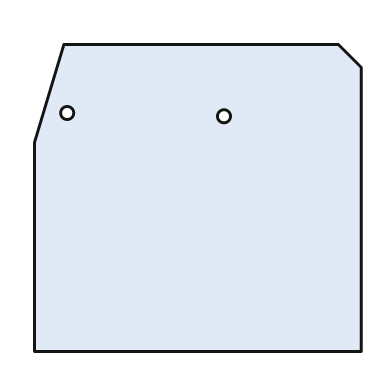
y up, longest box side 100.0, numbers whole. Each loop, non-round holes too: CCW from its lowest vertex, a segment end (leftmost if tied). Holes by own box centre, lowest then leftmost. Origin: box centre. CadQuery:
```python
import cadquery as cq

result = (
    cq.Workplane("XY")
    .moveTo(-50.0, -47.0)
    .lineTo(50.0, -47.0)
    .lineTo(50.0, 40.0)
    .lineTo(43.0, 47.0)
    .lineTo(-41.0, 47.0)
    .lineTo(-50.0, 17.0)
    .close()
    .moveTo(8.0, 25.0)
    .circle(2.0)
    .moveTo(-40.0, 26.0)
    .circle(2.0)
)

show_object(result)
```